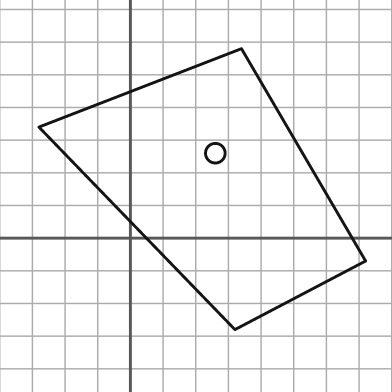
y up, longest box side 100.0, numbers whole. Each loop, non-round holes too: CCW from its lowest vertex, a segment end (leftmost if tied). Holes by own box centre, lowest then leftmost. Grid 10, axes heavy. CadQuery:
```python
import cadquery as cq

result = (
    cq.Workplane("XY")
    .moveTo(32.0, -28.0)
    .lineTo(72.0, -7.0)
    .lineTo(34.0, 58.0)
    .lineTo(-28.0, 34.0)
    .close()
    .moveTo(26.0, 26.0)
    .circle(3.0)
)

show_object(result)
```